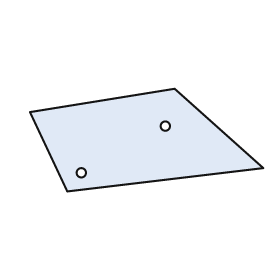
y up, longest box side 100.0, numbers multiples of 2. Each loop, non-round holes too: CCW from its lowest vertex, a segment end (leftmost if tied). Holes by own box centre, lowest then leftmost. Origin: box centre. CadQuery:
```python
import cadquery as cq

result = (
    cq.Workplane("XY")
    .moveTo(-34.0, -22.0)
    .lineTo(50.0, -12.0)
    .lineTo(12.0, 22.0)
    .lineTo(-50.0, 12.0)
    .close()
    .moveTo(-28.0, -14.0)
    .circle(2.0)
    .moveTo(8.0, 6.0)
    .circle(2.0)
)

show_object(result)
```